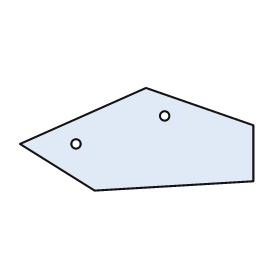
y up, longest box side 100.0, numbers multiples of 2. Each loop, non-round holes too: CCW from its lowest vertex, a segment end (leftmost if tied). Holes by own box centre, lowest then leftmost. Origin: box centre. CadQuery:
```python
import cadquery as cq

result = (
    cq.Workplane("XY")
    .moveTo(-18.0, -22.0)
    .lineTo(50.0, -18.0)
    .lineTo(50.0, 6.0)
    .lineTo(4.0, 22.0)
    .lineTo(-50.0, -2.0)
    .close()
    .moveTo(-26.0, -2.0)
    .circle(2.0)
    .moveTo(12.0, 10.0)
    .circle(2.0)
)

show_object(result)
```